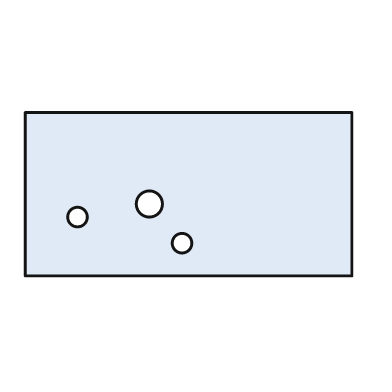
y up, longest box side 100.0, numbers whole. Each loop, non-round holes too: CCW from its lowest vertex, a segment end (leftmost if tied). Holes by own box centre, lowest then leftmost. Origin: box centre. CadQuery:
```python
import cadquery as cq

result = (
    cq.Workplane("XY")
    .moveTo(-50.0, -25.0)
    .lineTo(50.0, -25.0)
    .lineTo(50.0, 25.0)
    .lineTo(-50.0, 25.0)
    .close()
    .moveTo(-2.0, -15.0)
    .circle(3.0)
    .moveTo(-34.0, -7.0)
    .circle(3.0)
    .moveTo(-12.0, -3.0)
    .circle(4.0)
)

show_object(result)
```